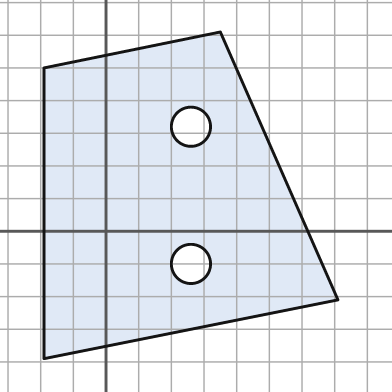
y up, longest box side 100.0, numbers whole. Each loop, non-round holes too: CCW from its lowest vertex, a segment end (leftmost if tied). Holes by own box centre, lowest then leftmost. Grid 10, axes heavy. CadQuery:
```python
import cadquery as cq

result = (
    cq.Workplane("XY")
    .moveTo(-19.0, -39.0)
    .lineTo(71.0, -21.0)
    .lineTo(35.0, 61.0)
    .lineTo(-19.0, 50.0)
    .close()
    .moveTo(26.0, -10.0)
    .circle(6.0)
    .moveTo(26.0, 32.0)
    .circle(6.0)
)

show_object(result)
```